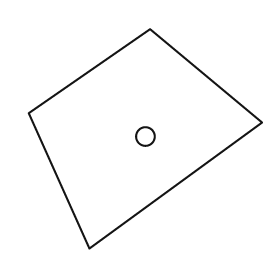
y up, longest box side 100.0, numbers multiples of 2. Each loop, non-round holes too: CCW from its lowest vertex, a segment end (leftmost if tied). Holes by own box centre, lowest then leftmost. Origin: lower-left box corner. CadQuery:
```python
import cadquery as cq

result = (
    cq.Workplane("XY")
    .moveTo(26.0, 0.0)
    .lineTo(100.0, 54.0)
    .lineTo(52.0, 94.0)
    .lineTo(0.0, 58.0)
    .close()
    .moveTo(50.0, 48.0)
    .circle(4.0)
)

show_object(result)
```